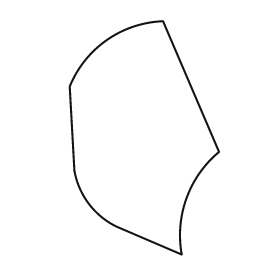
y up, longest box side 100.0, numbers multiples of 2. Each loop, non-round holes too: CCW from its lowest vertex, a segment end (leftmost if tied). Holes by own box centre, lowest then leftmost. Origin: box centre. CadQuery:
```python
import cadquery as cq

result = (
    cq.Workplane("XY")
    .moveTo(16.0, -50.0)
    .threePointArc((18.0, -26.0), (32.0, -6.0))
    .lineTo(8.0, 50.0)
    .threePointArc((-16.0, 42.0), (-32.0, 22.0))
    .lineTo(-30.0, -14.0)
    .threePointArc((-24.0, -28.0), (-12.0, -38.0))
    .close()
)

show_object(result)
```